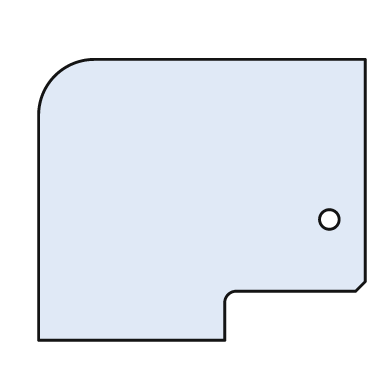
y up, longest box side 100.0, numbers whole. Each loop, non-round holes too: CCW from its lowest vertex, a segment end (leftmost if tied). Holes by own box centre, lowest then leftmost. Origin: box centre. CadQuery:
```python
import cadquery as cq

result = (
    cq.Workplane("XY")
    .moveTo(-50.0, -43.0)
    .lineTo(7.0, -43.0)
    .lineTo(7.0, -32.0)
    .threePointArc((8.0, -29.0), (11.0, -28.0))
    .lineTo(47.0, -28.0)
    .lineTo(50.0, -25.0)
    .lineTo(50.0, 43.0)
    .lineTo(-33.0, 43.0)
    .threePointArc((-45.0, 38.0), (-50.0, 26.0))
    .close()
    .moveTo(39.0, -6.0)
    .circle(3.0)
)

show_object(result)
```